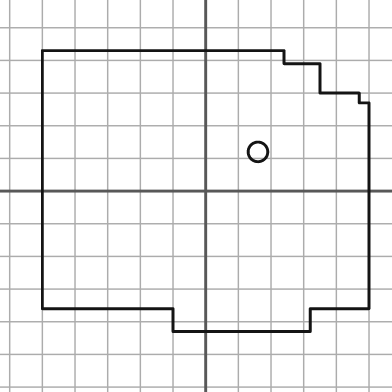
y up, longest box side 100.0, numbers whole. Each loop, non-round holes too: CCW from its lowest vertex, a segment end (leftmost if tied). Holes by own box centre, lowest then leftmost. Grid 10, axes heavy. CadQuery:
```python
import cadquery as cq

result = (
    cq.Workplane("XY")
    .moveTo(-10.0, -43.0)
    .lineTo(32.0, -43.0)
    .lineTo(32.0, -36.0)
    .lineTo(50.0, -36.0)
    .lineTo(50.0, 27.0)
    .lineTo(47.0, 27.0)
    .lineTo(47.0, 30.0)
    .lineTo(35.0, 30.0)
    .lineTo(35.0, 39.0)
    .lineTo(24.0, 39.0)
    .lineTo(24.0, 43.0)
    .lineTo(-50.0, 43.0)
    .lineTo(-50.0, -36.0)
    .lineTo(-10.0, -36.0)
    .close()
    .moveTo(16.0, 12.0)
    .circle(3.0)
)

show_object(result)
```